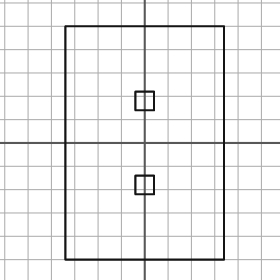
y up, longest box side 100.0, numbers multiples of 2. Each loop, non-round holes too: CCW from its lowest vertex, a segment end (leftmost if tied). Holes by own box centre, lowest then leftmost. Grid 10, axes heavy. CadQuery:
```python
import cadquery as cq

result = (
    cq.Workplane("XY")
    .moveTo(-34.0, -50.0)
    .lineTo(34.0, -50.0)
    .lineTo(34.0, 50.0)
    .lineTo(-34.0, 50.0)
    .close()
    .moveTo(-4.0, -22.0)
    .lineTo(4.0, -22.0)
    .lineTo(4.0, -14.0)
    .lineTo(-4.0, -14.0)
    .close()
    .moveTo(-4.0, 14.0)
    .lineTo(4.0, 14.0)
    .lineTo(4.0, 22.0)
    .lineTo(-4.0, 22.0)
    .close()
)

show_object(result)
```